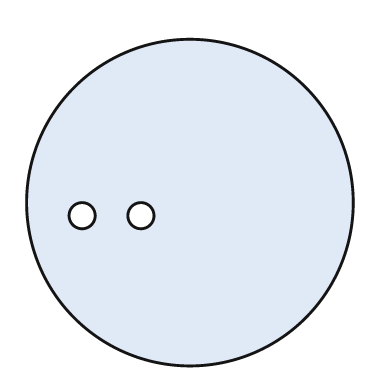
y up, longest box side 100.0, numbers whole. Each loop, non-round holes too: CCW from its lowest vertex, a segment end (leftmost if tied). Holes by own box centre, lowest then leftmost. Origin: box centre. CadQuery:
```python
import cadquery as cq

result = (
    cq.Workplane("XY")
    .moveTo(0.0, 0.0)
    .circle(50.0)
    .moveTo(-33.0, -4.0)
    .circle(4.0)
    .moveTo(-15.0, -4.0)
    .circle(4.0)
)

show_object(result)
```